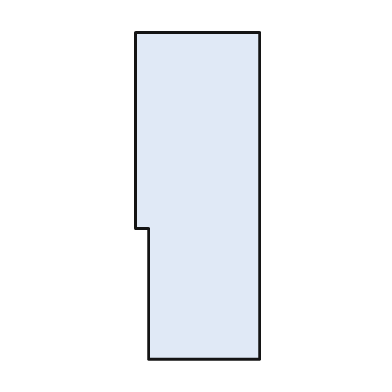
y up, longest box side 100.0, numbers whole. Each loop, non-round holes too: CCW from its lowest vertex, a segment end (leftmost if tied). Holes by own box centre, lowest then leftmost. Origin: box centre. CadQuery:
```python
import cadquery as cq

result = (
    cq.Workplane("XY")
    .moveTo(-15.0, -50.0)
    .lineTo(19.0, -50.0)
    .lineTo(19.0, 50.0)
    .lineTo(-19.0, 50.0)
    .lineTo(-19.0, -10.0)
    .lineTo(-15.0, -10.0)
    .close()
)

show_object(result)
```